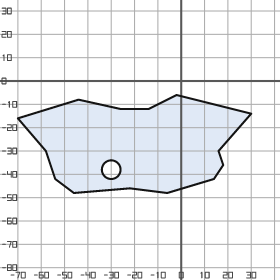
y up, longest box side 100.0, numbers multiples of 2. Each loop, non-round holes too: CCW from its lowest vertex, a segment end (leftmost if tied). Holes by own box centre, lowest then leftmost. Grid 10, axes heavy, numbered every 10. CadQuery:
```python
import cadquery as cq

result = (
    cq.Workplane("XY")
    .moveTo(-46.0, -48.0)
    .lineTo(-22.0, -46.0)
    .lineTo(-6.0, -48.0)
    .lineTo(14.0, -42.0)
    .lineTo(18.0, -36.0)
    .lineTo(16.0, -30.0)
    .lineTo(30.0, -14.0)
    .lineTo(-2.0, -6.0)
    .lineTo(-14.0, -12.0)
    .lineTo(-26.0, -12.0)
    .lineTo(-44.0, -8.0)
    .lineTo(-70.0, -16.0)
    .lineTo(-58.0, -30.0)
    .lineTo(-54.0, -42.0)
    .close()
    .moveTo(-30.0, -38.0)
    .circle(4.0)
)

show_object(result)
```